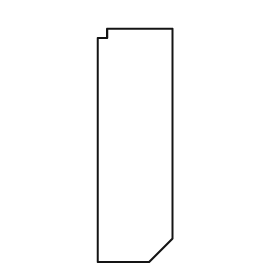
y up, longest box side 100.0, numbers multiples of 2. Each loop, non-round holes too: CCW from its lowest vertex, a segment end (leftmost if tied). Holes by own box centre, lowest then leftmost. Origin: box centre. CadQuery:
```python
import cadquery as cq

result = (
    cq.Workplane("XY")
    .moveTo(-16.0, -50.0)
    .lineTo(6.0, -50.0)
    .lineTo(16.0, -40.0)
    .lineTo(16.0, 50.0)
    .lineTo(-12.0, 50.0)
    .lineTo(-12.0, 46.0)
    .lineTo(-16.0, 46.0)
    .close()
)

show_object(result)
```